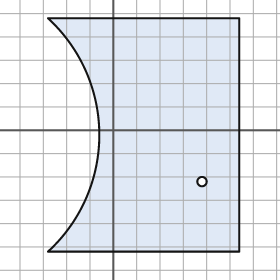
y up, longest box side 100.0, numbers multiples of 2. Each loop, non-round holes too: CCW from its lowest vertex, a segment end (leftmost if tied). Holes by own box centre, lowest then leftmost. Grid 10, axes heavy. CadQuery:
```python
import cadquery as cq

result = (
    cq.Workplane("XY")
    .moveTo(-28.0, -52.0)
    .lineTo(54.0, -52.0)
    .lineTo(54.0, 48.0)
    .lineTo(-28.0, 48.0)
    .threePointArc((-6.0, -2.0), (-28.0, -52.0))
    .close()
    .moveTo(38.0, -22.0)
    .circle(2.0)
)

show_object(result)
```